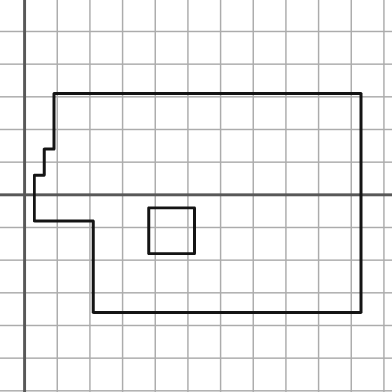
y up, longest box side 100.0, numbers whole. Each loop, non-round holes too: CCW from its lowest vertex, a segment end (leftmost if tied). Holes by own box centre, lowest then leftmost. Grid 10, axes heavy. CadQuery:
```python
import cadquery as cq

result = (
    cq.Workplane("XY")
    .moveTo(21.0, -36.0)
    .lineTo(103.0, -36.0)
    .lineTo(103.0, 31.0)
    .lineTo(9.0, 31.0)
    .lineTo(9.0, 14.0)
    .lineTo(6.0, 14.0)
    .lineTo(6.0, 6.0)
    .lineTo(3.0, 6.0)
    .lineTo(3.0, -8.0)
    .lineTo(21.0, -8.0)
    .close()
    .moveTo(38.0, -18.0)
    .lineTo(52.0, -18.0)
    .lineTo(52.0, -4.0)
    .lineTo(38.0, -4.0)
    .close()
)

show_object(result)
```